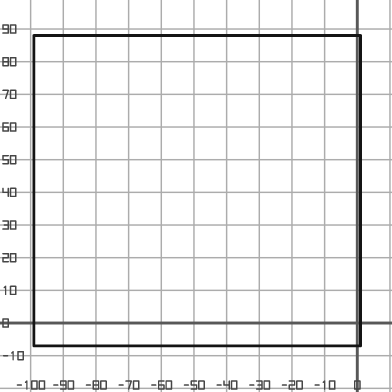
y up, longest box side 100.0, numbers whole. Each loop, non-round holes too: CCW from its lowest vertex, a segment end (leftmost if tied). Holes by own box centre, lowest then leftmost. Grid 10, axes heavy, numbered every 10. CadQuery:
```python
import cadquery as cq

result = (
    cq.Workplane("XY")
    .moveTo(-99.0, -7.0)
    .lineTo(1.0, -7.0)
    .lineTo(1.0, 88.0)
    .lineTo(-99.0, 88.0)
    .close()
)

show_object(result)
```